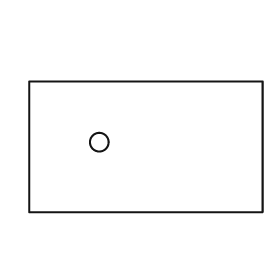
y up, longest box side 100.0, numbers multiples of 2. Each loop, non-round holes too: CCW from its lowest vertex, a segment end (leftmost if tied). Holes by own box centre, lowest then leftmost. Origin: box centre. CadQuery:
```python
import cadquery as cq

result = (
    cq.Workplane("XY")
    .moveTo(-50.0, -28.0)
    .lineTo(50.0, -28.0)
    .lineTo(50.0, 28.0)
    .lineTo(-50.0, 28.0)
    .close()
    .moveTo(-20.0, 2.0)
    .circle(4.0)
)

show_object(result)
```